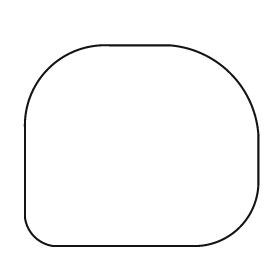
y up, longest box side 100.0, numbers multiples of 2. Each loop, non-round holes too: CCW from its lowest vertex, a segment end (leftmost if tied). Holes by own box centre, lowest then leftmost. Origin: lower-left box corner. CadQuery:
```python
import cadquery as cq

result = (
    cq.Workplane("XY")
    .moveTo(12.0, 0.0)
    .lineTo(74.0, 0.0)
    .threePointArc((92.0, 8.0), (100.0, 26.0))
    .lineTo(100.0, 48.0)
    .threePointArc((88.0, 74.0), (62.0, 86.0))
    .lineTo(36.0, 86.0)
    .threePointArc((10.0, 76.0), (0.0, 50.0))
    .lineTo(0.0, 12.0)
    .threePointArc((4.0, 4.0), (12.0, 0.0))
    .close()
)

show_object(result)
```